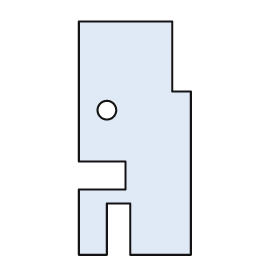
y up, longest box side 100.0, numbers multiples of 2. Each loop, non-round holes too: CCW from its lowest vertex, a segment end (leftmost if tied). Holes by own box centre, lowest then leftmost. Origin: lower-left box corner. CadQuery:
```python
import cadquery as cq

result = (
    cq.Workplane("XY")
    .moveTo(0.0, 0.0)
    .lineTo(12.0, 0.0)
    .lineTo(12.0, 22.0)
    .lineTo(22.0, 22.0)
    .lineTo(22.0, 0.0)
    .lineTo(48.0, 0.0)
    .lineTo(48.0, 70.0)
    .lineTo(40.0, 70.0)
    .lineTo(40.0, 100.0)
    .lineTo(0.0, 100.0)
    .lineTo(0.0, 40.0)
    .lineTo(20.0, 40.0)
    .lineTo(20.0, 28.0)
    .lineTo(0.0, 28.0)
    .close()
    .moveTo(12.0, 62.0)
    .circle(4.0)
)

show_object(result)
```